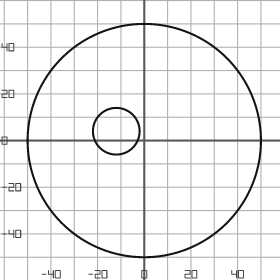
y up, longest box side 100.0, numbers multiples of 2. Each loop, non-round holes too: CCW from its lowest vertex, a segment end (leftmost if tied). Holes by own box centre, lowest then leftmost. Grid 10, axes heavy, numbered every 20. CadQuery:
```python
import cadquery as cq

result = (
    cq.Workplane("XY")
    .moveTo(0.0, 0.0)
    .circle(50.0)
    .moveTo(-12.0, 4.0)
    .circle(10.0)
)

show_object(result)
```